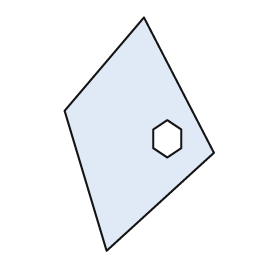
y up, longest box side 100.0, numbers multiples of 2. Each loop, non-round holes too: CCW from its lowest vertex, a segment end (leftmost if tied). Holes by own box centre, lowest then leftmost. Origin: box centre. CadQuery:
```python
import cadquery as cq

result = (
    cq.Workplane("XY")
    .moveTo(-14.0, -50.0)
    .lineTo(32.0, -8.0)
    .lineTo(2.0, 50.0)
    .lineTo(-32.0, 10.0)
    .close()
    .moveTo(12.0, -10.0)
    .lineTo(18.0, -6.0)
    .lineTo(18.0, 2.0)
    .lineTo(12.0, 6.0)
    .lineTo(6.0, 2.0)
    .lineTo(6.0, -6.0)
    .close()
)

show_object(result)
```